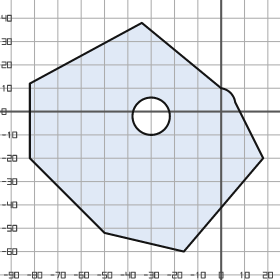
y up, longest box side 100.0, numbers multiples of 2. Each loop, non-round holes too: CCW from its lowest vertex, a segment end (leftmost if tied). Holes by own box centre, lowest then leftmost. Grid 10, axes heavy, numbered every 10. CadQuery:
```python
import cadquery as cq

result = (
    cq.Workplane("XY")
    .moveTo(-16.0, -60.0)
    .lineTo(18.0, -20.0)
    .lineTo(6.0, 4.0)
    .threePointArc((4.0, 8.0), (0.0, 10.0))
    .lineTo(-34.0, 38.0)
    .lineTo(-82.0, 12.0)
    .lineTo(-82.0, -20.0)
    .lineTo(-50.0, -52.0)
    .close()
    .moveTo(-30.0, -2.0)
    .circle(8.0)
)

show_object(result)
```